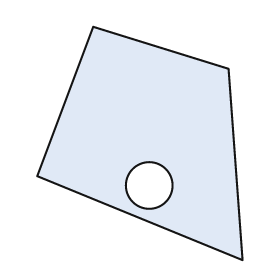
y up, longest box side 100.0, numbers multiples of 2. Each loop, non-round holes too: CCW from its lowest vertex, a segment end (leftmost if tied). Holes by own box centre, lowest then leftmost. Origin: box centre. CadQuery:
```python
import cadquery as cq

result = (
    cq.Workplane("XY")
    .moveTo(44.0, -50.0)
    .lineTo(38.0, 32.0)
    .lineTo(-20.0, 50.0)
    .lineTo(-44.0, -14.0)
    .close()
    .moveTo(4.0, -18.0)
    .circle(10.0)
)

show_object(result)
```